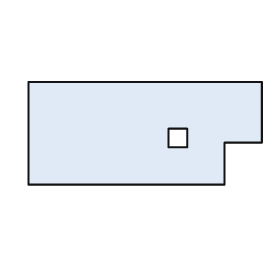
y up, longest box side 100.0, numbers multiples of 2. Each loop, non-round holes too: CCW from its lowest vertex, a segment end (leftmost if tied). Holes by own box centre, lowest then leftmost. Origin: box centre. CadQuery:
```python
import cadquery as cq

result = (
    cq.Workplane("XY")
    .moveTo(-50.0, -22.0)
    .lineTo(34.0, -22.0)
    .lineTo(34.0, -4.0)
    .lineTo(50.0, -4.0)
    .lineTo(50.0, 22.0)
    .lineTo(-50.0, 22.0)
    .close()
    .moveTo(10.0, -6.0)
    .lineTo(18.0, -6.0)
    .lineTo(18.0, 2.0)
    .lineTo(10.0, 2.0)
    .close()
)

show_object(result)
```